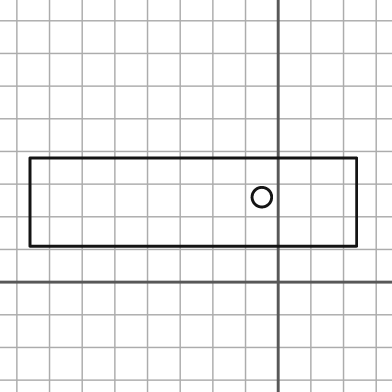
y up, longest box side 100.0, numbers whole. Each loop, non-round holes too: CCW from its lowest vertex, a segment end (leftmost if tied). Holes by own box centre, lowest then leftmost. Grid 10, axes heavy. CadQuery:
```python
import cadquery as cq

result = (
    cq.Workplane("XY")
    .moveTo(-76.0, 11.0)
    .lineTo(24.0, 11.0)
    .lineTo(24.0, 38.0)
    .lineTo(-76.0, 38.0)
    .close()
    .moveTo(-5.0, 26.0)
    .circle(3.0)
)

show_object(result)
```